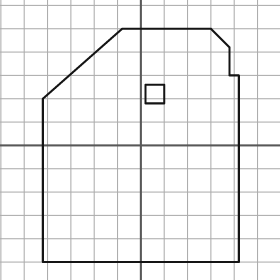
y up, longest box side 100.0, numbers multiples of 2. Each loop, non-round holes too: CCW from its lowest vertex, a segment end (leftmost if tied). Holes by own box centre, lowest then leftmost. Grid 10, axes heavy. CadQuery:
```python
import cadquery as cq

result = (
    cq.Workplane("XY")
    .moveTo(-42.0, -50.0)
    .lineTo(42.0, -50.0)
    .lineTo(42.0, 30.0)
    .lineTo(38.0, 30.0)
    .lineTo(38.0, 42.0)
    .lineTo(30.0, 50.0)
    .lineTo(-8.0, 50.0)
    .lineTo(-42.0, 20.0)
    .close()
    .moveTo(2.0, 18.0)
    .lineTo(10.0, 18.0)
    .lineTo(10.0, 26.0)
    .lineTo(2.0, 26.0)
    .close()
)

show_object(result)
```